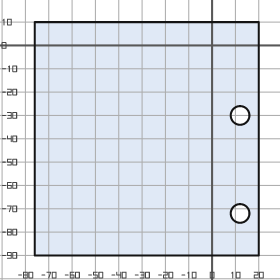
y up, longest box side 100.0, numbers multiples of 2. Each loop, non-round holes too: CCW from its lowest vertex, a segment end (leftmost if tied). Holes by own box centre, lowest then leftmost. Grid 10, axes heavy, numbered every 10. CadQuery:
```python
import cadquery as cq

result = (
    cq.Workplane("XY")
    .moveTo(-76.0, -90.0)
    .lineTo(20.0, -90.0)
    .lineTo(20.0, 10.0)
    .lineTo(-76.0, 10.0)
    .close()
    .moveTo(12.0, -72.0)
    .circle(4.0)
    .moveTo(12.0, -30.0)
    .circle(4.0)
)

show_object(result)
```